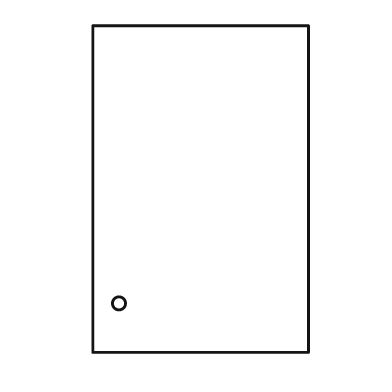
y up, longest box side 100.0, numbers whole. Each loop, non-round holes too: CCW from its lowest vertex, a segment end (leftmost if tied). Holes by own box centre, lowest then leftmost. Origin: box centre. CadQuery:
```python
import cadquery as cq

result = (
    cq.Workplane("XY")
    .moveTo(-33.0, -50.0)
    .lineTo(33.0, -50.0)
    .lineTo(33.0, 50.0)
    .lineTo(-33.0, 50.0)
    .close()
    .moveTo(-25.0, -35.0)
    .circle(2.0)
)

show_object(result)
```